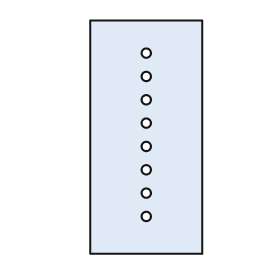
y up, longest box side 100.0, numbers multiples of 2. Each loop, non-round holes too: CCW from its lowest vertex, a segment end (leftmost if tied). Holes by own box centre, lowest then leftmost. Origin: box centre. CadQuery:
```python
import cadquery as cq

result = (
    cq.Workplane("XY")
    .moveTo(-24.0, -50.0)
    .lineTo(24.0, -50.0)
    .lineTo(24.0, 50.0)
    .lineTo(-24.0, 50.0)
    .close()
    .moveTo(0.0, -34.0)
    .circle(2.0)
    .moveTo(0.0, -24.0)
    .circle(2.0)
    .moveTo(0.0, -14.0)
    .circle(2.0)
    .moveTo(0.0, -4.0)
    .circle(2.0)
    .moveTo(0.0, 6.0)
    .circle(2.0)
    .moveTo(0.0, 16.0)
    .circle(2.0)
    .moveTo(0.0, 26.0)
    .circle(2.0)
    .moveTo(0.0, 36.0)
    .circle(2.0)
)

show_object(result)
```